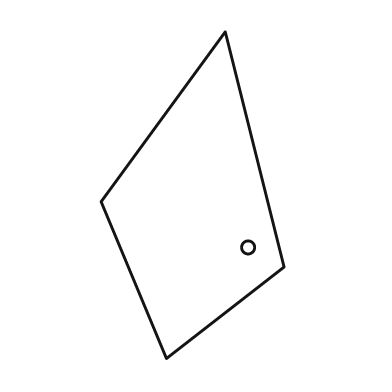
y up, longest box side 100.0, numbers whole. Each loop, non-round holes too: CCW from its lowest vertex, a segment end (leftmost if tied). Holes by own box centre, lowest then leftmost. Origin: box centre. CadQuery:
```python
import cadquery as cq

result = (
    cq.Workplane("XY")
    .moveTo(-8.0, -50.0)
    .lineTo(28.0, -22.0)
    .lineTo(10.0, 50.0)
    .lineTo(-28.0, -2.0)
    .close()
    .moveTo(17.0, -16.0)
    .circle(2.0)
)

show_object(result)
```